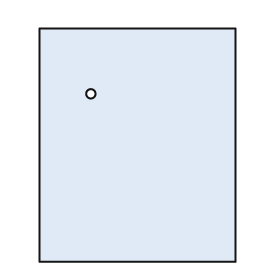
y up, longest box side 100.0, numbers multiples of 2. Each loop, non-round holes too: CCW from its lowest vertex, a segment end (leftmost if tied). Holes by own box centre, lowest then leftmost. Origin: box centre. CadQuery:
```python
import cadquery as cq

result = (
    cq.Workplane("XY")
    .moveTo(-42.0, -50.0)
    .lineTo(42.0, -50.0)
    .lineTo(42.0, 50.0)
    .lineTo(-42.0, 50.0)
    .close()
    .moveTo(-20.0, 22.0)
    .circle(2.0)
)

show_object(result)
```